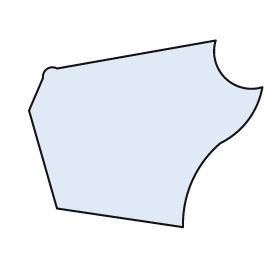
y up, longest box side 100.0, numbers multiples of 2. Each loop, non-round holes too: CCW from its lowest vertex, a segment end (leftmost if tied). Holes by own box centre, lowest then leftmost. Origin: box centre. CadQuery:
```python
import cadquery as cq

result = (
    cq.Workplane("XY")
    .moveTo(16.0, -40.0)
    .threePointArc((20.0, -20.0), (32.0, -4.0))
    .threePointArc((44.0, 6.0), (50.0, 20.0))
    .threePointArc((34.0, 24.0), (30.0, 40.0))
    .lineTo(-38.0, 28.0)
    .threePointArc((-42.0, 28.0), (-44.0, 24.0))
    .lineTo(-50.0, 10.0)
    .lineTo(-38.0, -32.0)
    .close()
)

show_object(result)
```